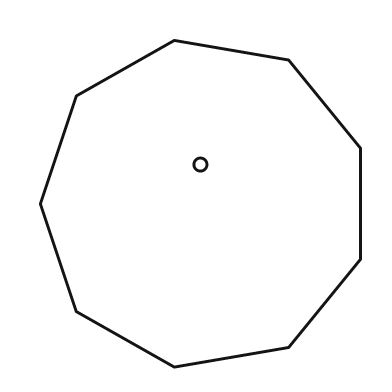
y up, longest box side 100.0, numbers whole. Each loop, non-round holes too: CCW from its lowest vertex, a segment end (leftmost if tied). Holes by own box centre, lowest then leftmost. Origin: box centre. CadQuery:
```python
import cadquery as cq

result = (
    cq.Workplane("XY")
    .moveTo(-8.0, -50.0)
    .lineTo(27.0, -44.0)
    .lineTo(49.0, -17.0)
    .lineTo(49.0, 17.0)
    .lineTo(27.0, 44.0)
    .lineTo(-8.0, 50.0)
    .lineTo(-38.0, 33.0)
    .lineTo(-49.0, 0.0)
    .lineTo(-38.0, -33.0)
    .close()
    .moveTo(0.0, 12.0)
    .circle(2.0)
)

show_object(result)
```